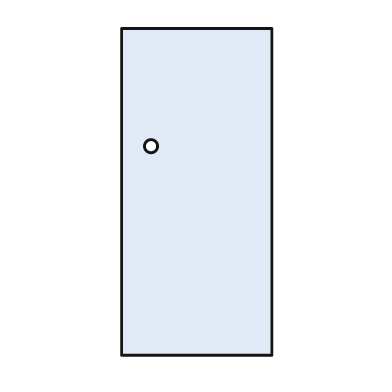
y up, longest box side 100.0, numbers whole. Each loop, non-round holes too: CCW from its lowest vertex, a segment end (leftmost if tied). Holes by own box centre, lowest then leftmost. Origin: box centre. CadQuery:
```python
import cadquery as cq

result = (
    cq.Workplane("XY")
    .moveTo(-23.0, -50.0)
    .lineTo(23.0, -50.0)
    .lineTo(23.0, 50.0)
    .lineTo(-23.0, 50.0)
    .close()
    .moveTo(-14.0, 14.0)
    .circle(2.0)
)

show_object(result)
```